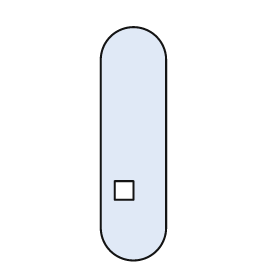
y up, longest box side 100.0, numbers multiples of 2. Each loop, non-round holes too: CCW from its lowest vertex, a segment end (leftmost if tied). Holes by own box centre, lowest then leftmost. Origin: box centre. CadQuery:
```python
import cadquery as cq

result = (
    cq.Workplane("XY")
    .moveTo(-14.0, -36.0)
    .threePointArc((0.0, -50.0), (14.0, -36.0))
    .lineTo(14.0, 36.0)
    .threePointArc((0.0, 50.0), (-14.0, 36.0))
    .close()
    .moveTo(-8.0, -24.0)
    .lineTo(0.0, -24.0)
    .lineTo(0.0, -16.0)
    .lineTo(-8.0, -16.0)
    .close()
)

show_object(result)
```